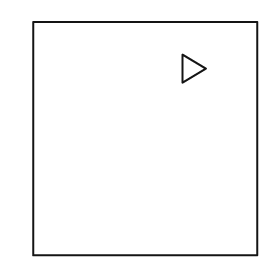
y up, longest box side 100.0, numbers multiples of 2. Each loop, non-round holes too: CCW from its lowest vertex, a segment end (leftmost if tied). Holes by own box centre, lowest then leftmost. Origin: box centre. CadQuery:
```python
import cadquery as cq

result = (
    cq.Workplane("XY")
    .moveTo(-48.0, -50.0)
    .lineTo(48.0, -50.0)
    .lineTo(48.0, 50.0)
    .lineTo(-48.0, 50.0)
    .close()
    .moveTo(16.0, 24.0)
    .lineTo(26.0, 30.0)
    .lineTo(16.0, 36.0)
    .close()
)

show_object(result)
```